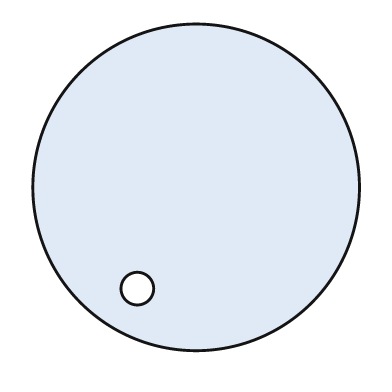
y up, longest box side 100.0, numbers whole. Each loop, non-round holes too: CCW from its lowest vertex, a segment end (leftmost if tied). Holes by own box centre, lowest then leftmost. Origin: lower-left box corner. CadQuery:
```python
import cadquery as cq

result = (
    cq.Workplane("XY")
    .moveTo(50.0, 50.0)
    .circle(50.0)
    .moveTo(32.0, 19.0)
    .circle(5.0)
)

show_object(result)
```